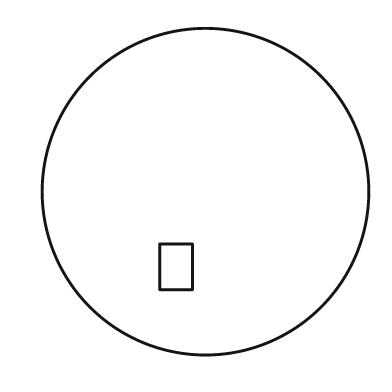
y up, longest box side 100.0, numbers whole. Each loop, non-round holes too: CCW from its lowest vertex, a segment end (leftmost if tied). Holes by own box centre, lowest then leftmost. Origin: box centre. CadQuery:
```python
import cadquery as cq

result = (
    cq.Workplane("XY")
    .moveTo(0.0, 0.0)
    .circle(50.0)
    .moveTo(-14.0, -30.0)
    .lineTo(-4.0, -30.0)
    .lineTo(-4.0, -16.0)
    .lineTo(-14.0, -16.0)
    .close()
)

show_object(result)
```